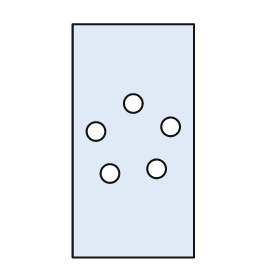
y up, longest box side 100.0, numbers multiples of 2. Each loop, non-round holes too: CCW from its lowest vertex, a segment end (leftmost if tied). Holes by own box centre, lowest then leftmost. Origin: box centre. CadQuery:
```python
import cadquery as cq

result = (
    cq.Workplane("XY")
    .moveTo(-26.0, -50.0)
    .lineTo(26.0, -50.0)
    .lineTo(26.0, 50.0)
    .lineTo(-26.0, 50.0)
    .close()
    .moveTo(-10.0, -14.0)
    .circle(4.0)
    .moveTo(10.0, -12.0)
    .circle(4.0)
    .moveTo(-16.0, 4.0)
    .circle(4.0)
    .moveTo(16.0, 6.0)
    .circle(4.0)
    .moveTo(0.0, 16.0)
    .circle(4.0)
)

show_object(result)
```